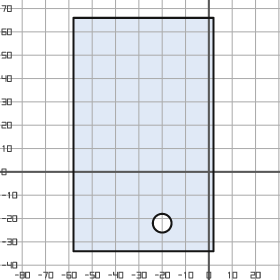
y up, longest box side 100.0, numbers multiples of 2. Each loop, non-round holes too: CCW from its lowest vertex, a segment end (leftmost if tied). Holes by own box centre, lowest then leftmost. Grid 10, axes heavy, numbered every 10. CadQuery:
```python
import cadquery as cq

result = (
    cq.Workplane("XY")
    .moveTo(-58.0, -34.0)
    .lineTo(2.0, -34.0)
    .lineTo(2.0, 66.0)
    .lineTo(-58.0, 66.0)
    .close()
    .moveTo(-20.0, -22.0)
    .circle(4.0)
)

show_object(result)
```